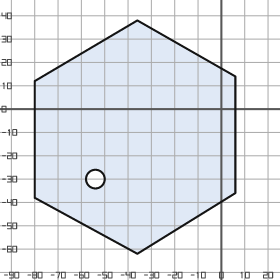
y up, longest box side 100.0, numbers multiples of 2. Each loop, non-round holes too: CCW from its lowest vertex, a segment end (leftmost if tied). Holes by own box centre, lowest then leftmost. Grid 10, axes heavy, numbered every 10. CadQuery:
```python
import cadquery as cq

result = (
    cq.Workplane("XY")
    .moveTo(-36.0, -62.0)
    .lineTo(6.0, -36.0)
    .lineTo(6.0, 14.0)
    .lineTo(-36.0, 38.0)
    .lineTo(-80.0, 12.0)
    .lineTo(-80.0, -38.0)
    .close()
    .moveTo(-54.0, -30.0)
    .circle(4.0)
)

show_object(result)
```